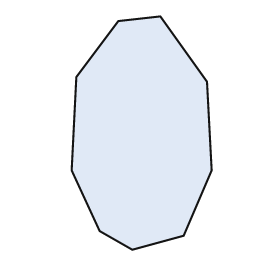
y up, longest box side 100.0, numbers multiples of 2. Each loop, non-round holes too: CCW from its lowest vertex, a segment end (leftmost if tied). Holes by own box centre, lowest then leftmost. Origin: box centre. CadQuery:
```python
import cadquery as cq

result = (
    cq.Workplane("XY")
    .moveTo(-4.0, -50.0)
    .lineTo(18.0, -44.0)
    .lineTo(30.0, -16.0)
    .lineTo(28.0, 22.0)
    .lineTo(8.0, 50.0)
    .lineTo(-10.0, 48.0)
    .lineTo(-28.0, 24.0)
    .lineTo(-30.0, -16.0)
    .lineTo(-18.0, -42.0)
    .close()
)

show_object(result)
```